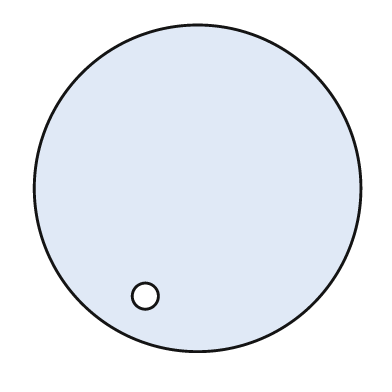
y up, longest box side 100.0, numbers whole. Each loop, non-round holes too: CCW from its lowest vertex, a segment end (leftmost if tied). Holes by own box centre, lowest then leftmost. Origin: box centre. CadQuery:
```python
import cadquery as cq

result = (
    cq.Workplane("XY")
    .moveTo(0.0, 0.0)
    .circle(50.0)
    .moveTo(-16.0, -33.0)
    .circle(4.0)
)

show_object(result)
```